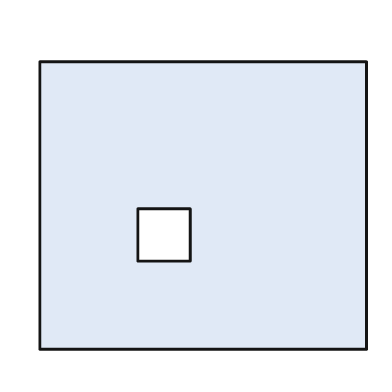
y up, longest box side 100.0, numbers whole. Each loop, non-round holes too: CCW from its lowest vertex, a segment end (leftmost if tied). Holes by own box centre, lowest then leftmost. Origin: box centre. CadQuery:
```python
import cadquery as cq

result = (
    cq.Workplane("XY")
    .moveTo(-50.0, -44.0)
    .lineTo(50.0, -44.0)
    .lineTo(50.0, 44.0)
    .lineTo(-50.0, 44.0)
    .close()
    .moveTo(-20.0, -17.0)
    .lineTo(-4.0, -17.0)
    .lineTo(-4.0, -1.0)
    .lineTo(-20.0, -1.0)
    .close()
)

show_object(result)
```